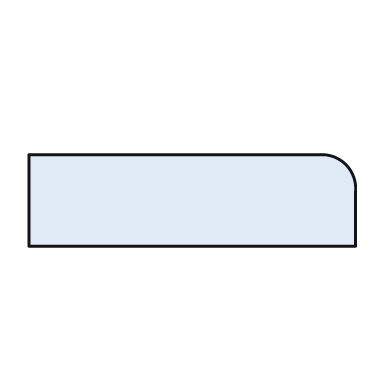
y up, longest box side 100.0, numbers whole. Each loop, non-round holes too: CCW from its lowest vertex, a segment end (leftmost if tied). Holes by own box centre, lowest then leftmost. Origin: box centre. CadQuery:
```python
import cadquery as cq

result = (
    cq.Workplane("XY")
    .moveTo(-50.0, -14.0)
    .lineTo(50.0, -14.0)
    .lineTo(50.0, 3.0)
    .threePointArc((47.0, 11.0), (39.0, 14.0))
    .lineTo(-50.0, 14.0)
    .close()
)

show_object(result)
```